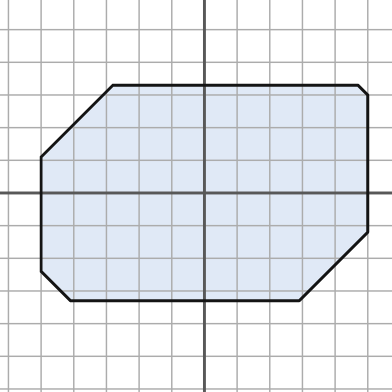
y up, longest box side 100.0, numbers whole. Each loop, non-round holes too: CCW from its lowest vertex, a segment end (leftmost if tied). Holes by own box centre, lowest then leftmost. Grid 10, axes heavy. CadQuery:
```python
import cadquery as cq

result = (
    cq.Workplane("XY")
    .moveTo(-41.0, -33.0)
    .lineTo(29.0, -33.0)
    .lineTo(50.0, -12.0)
    .lineTo(50.0, 30.0)
    .lineTo(47.0, 33.0)
    .lineTo(-28.0, 33.0)
    .lineTo(-50.0, 11.0)
    .lineTo(-50.0, -24.0)
    .close()
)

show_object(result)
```